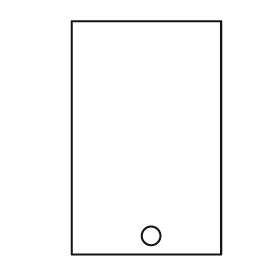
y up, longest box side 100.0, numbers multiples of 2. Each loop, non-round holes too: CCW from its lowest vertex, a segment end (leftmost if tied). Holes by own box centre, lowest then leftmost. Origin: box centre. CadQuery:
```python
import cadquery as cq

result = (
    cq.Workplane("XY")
    .moveTo(-32.0, -50.0)
    .lineTo(32.0, -50.0)
    .lineTo(32.0, 50.0)
    .lineTo(-32.0, 50.0)
    .close()
    .moveTo(2.0, -42.0)
    .circle(4.0)
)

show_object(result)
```